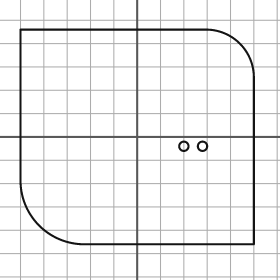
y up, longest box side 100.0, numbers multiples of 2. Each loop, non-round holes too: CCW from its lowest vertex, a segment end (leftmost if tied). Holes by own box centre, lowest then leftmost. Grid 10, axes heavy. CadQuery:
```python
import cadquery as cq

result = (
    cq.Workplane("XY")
    .moveTo(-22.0, -46.0)
    .lineTo(50.0, -46.0)
    .lineTo(50.0, 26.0)
    .threePointArc((44.0, 40.0), (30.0, 46.0))
    .lineTo(-50.0, 46.0)
    .lineTo(-50.0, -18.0)
    .threePointArc((-42.0, -38.0), (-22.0, -46.0))
    .close()
    .moveTo(20.0, -4.0)
    .circle(2.0)
    .moveTo(28.0, -4.0)
    .circle(2.0)
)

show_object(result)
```